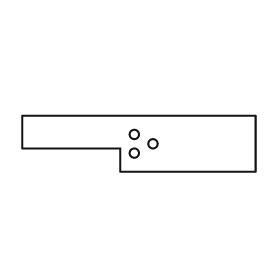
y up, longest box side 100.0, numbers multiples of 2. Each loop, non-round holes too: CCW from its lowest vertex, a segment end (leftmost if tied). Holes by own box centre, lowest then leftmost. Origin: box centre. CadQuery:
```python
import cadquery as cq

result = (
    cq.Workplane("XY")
    .moveTo(-8.0, -12.0)
    .lineTo(50.0, -12.0)
    .lineTo(50.0, 12.0)
    .lineTo(-50.0, 12.0)
    .lineTo(-50.0, -2.0)
    .lineTo(-8.0, -2.0)
    .close()
    .moveTo(-2.0, -4.0)
    .circle(2.0)
    .moveTo(6.0, 0.0)
    .circle(2.0)
    .moveTo(-2.0, 4.0)
    .circle(2.0)
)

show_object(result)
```